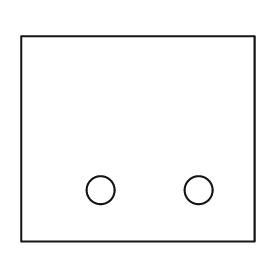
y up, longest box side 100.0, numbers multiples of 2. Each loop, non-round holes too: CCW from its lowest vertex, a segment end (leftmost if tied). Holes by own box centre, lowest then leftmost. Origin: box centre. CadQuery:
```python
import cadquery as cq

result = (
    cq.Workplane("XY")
    .moveTo(-50.0, -44.0)
    .lineTo(50.0, -44.0)
    .lineTo(50.0, 44.0)
    .lineTo(-50.0, 44.0)
    .close()
    .moveTo(-16.0, -22.0)
    .circle(6.0)
    .moveTo(26.0, -22.0)
    .circle(6.0)
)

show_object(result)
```